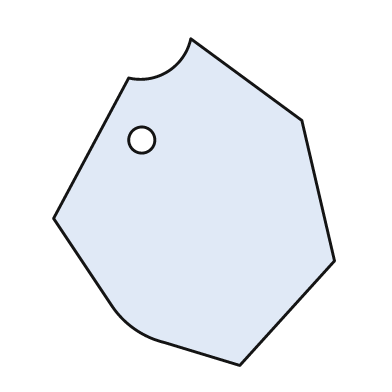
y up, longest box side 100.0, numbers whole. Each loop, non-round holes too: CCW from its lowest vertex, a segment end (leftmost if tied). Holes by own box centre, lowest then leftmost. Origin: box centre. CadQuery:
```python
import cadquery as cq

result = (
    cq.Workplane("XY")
    .moveTo(14.0, -50.0)
    .lineTo(43.0, -18.0)
    .lineTo(33.0, 25.0)
    .lineTo(-1.0, 50.0)
    .threePointArc((-8.0, 40.0), (-20.0, 38.0))
    .lineTo(-43.0, -5.0)
    .lineTo(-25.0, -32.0)
    .threePointArc((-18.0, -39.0), (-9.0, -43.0))
    .close()
    .moveTo(-16.0, 19.0)
    .circle(4.0)
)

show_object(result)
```